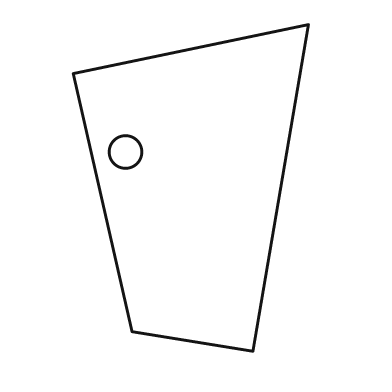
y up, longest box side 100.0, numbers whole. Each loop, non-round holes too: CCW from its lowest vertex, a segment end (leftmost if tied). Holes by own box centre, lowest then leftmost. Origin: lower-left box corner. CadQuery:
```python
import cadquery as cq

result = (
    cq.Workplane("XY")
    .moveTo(55.0, 0.0)
    .lineTo(72.0, 100.0)
    .lineTo(0.0, 85.0)
    .lineTo(18.0, 6.0)
    .close()
    .moveTo(16.0, 61.0)
    .circle(5.0)
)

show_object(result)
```